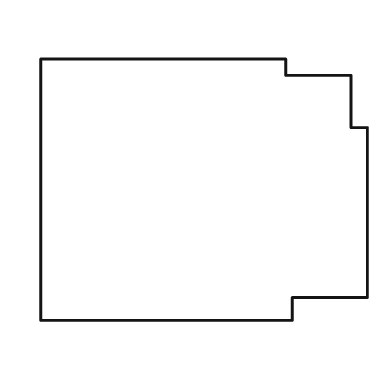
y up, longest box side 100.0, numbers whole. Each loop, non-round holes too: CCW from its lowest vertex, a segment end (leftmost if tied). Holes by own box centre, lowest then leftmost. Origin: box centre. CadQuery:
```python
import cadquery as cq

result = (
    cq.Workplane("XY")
    .moveTo(-50.0, -40.0)
    .lineTo(27.0, -40.0)
    .lineTo(27.0, -33.0)
    .lineTo(50.0, -33.0)
    .lineTo(50.0, 19.0)
    .lineTo(45.0, 19.0)
    .lineTo(45.0, 35.0)
    .lineTo(25.0, 35.0)
    .lineTo(25.0, 40.0)
    .lineTo(-50.0, 40.0)
    .close()
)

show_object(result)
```